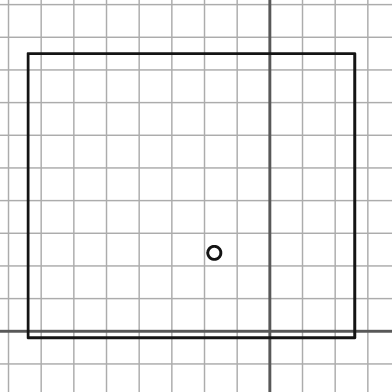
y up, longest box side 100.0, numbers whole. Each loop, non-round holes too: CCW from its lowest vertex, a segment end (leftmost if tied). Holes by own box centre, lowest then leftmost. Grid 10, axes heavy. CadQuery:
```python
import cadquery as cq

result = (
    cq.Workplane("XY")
    .moveTo(-74.0, -2.0)
    .lineTo(26.0, -2.0)
    .lineTo(26.0, 85.0)
    .lineTo(-74.0, 85.0)
    .close()
    .moveTo(-17.0, 24.0)
    .circle(2.0)
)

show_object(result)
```